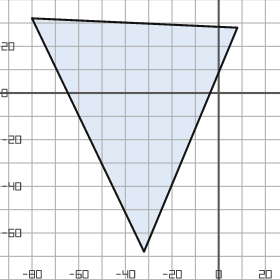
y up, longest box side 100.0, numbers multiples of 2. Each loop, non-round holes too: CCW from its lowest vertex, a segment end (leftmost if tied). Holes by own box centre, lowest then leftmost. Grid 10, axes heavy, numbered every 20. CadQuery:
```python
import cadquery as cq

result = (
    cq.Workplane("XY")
    .moveTo(-32.0, -68.0)
    .lineTo(8.0, 28.0)
    .lineTo(-80.0, 32.0)
    .close()
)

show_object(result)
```